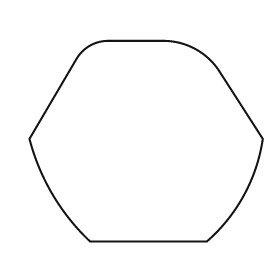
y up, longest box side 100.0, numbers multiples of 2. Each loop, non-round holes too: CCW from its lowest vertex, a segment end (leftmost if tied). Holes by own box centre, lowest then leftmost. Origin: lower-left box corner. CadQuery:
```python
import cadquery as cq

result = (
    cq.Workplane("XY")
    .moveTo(26.0, 0.0)
    .lineTo(76.0, 0.0)
    .threePointArc((92.0, 20.0), (100.0, 44.0))
    .lineTo(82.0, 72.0)
    .threePointArc((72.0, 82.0), (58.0, 86.0))
    .lineTo(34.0, 86.0)
    .threePointArc((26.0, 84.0), (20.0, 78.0))
    .lineTo(0.0, 44.0)
    .threePointArc((10.0, 20.0), (26.0, 0.0))
    .close()
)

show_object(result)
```